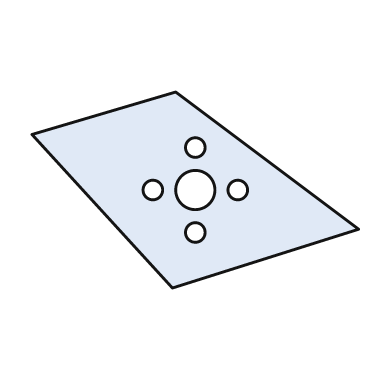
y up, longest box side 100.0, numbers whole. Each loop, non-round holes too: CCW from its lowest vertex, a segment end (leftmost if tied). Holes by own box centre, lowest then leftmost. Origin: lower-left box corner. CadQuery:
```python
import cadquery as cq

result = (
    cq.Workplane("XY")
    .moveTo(43.0, 0.0)
    .lineTo(100.0, 18.0)
    .lineTo(44.0, 60.0)
    .lineTo(0.0, 47.0)
    .close()
    .moveTo(50.0, 17.0)
    .circle(3.0)
    .moveTo(37.0, 30.0)
    .circle(3.0)
    .moveTo(50.0, 30.0)
    .circle(6.0)
    .moveTo(63.0, 30.0)
    .circle(3.0)
    .moveTo(50.0, 43.0)
    .circle(3.0)
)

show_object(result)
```